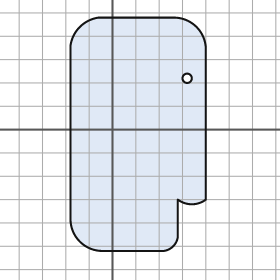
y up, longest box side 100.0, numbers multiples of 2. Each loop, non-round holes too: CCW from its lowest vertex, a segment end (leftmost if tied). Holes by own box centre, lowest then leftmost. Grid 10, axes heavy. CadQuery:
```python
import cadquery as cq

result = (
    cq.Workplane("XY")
    .moveTo(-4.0, -52.0)
    .lineTo(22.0, -52.0)
    .threePointArc((26.0, -50.0), (28.0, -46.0))
    .lineTo(28.0, -30.0)
    .threePointArc((34.0, -32.0), (40.0, -30.0))
    .lineTo(40.0, 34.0)
    .threePointArc((36.0, 44.0), (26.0, 48.0))
    .lineTo(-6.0, 48.0)
    .threePointArc((-14.0, 44.0), (-18.0, 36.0))
    .lineTo(-18.0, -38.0)
    .threePointArc((-14.0, -48.0), (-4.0, -52.0))
    .close()
    .moveTo(32.0, 22.0)
    .circle(2.0)
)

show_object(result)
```